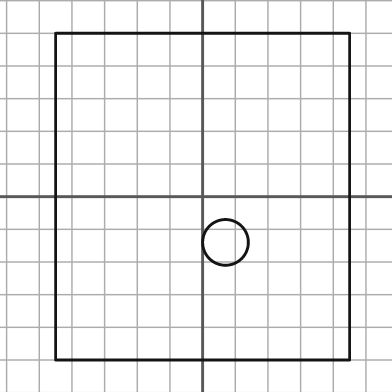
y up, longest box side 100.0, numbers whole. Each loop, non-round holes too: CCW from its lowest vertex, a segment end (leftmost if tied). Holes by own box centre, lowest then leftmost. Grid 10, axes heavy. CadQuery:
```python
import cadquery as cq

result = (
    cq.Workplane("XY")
    .moveTo(-45.0, -50.0)
    .lineTo(45.0, -50.0)
    .lineTo(45.0, 50.0)
    .lineTo(-45.0, 50.0)
    .close()
    .moveTo(7.0, -14.0)
    .circle(7.0)
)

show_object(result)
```